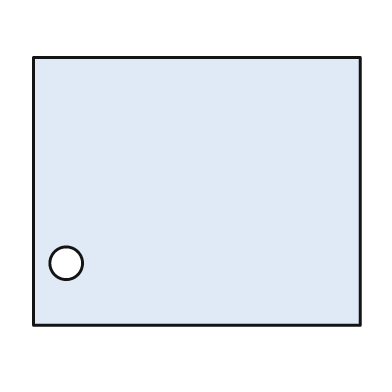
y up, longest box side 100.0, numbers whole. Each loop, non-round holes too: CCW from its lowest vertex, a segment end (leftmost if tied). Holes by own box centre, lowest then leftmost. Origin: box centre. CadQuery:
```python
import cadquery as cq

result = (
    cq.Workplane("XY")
    .moveTo(-50.0, -41.0)
    .lineTo(50.0, -41.0)
    .lineTo(50.0, 41.0)
    .lineTo(-50.0, 41.0)
    .close()
    .moveTo(-40.0, -22.0)
    .circle(5.0)
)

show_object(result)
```